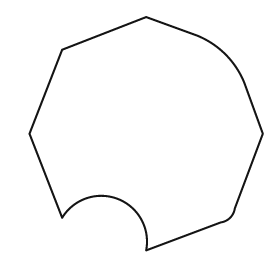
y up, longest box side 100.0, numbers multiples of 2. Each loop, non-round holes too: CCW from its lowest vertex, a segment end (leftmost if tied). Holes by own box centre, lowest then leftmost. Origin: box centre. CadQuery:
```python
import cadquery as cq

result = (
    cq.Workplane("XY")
    .moveTo(0.0, -50.0)
    .lineTo(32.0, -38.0)
    .threePointArc((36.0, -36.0), (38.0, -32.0))
    .lineTo(50.0, 0.0)
    .lineTo(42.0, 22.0)
    .threePointArc((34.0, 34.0), (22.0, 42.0))
    .lineTo(0.0, 50.0)
    .lineTo(-36.0, 36.0)
    .lineTo(-50.0, 0.0)
    .lineTo(-36.0, -36.0)
    .threePointArc((-12.0, -28.0), (0.0, -50.0))
    .close()
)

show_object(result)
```